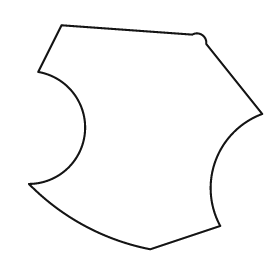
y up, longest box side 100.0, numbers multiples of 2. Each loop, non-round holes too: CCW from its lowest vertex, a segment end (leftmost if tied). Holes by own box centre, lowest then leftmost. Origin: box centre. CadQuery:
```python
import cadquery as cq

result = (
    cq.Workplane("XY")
    .moveTo(2.0, -48.0)
    .lineTo(32.0, -38.0)
    .threePointArc((30.0, -10.0), (50.0, 10.0))
    .lineTo(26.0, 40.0)
    .threePointArc((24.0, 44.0), (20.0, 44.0))
    .lineTo(-36.0, 48.0)
    .lineTo(-46.0, 28.0)
    .threePointArc((-26.0, 2.0), (-50.0, -20.0))
    .threePointArc((-26.0, -38.0), (2.0, -48.0))
    .close()
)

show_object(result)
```